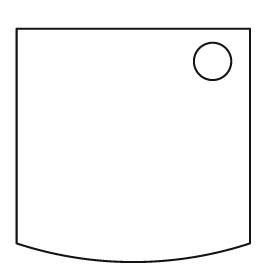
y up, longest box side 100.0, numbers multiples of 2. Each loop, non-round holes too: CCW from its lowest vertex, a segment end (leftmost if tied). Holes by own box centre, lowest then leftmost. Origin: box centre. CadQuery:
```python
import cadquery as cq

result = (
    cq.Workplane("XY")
    .moveTo(-50.0, -42.0)
    .threePointArc((0.0, -50.0), (50.0, -42.0))
    .lineTo(50.0, 50.0)
    .lineTo(-50.0, 50.0)
    .close()
    .moveTo(34.0, 36.0)
    .circle(8.0)
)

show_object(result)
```